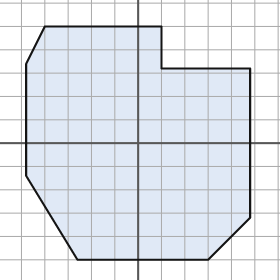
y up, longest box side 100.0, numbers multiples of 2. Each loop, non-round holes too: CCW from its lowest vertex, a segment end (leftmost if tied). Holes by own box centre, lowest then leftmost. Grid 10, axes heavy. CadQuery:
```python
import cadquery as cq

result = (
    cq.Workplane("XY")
    .moveTo(-26.0, -50.0)
    .lineTo(30.0, -50.0)
    .lineTo(48.0, -32.0)
    .lineTo(48.0, 32.0)
    .lineTo(10.0, 32.0)
    .lineTo(10.0, 50.0)
    .lineTo(-40.0, 50.0)
    .lineTo(-48.0, 34.0)
    .lineTo(-48.0, -14.0)
    .close()
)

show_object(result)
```